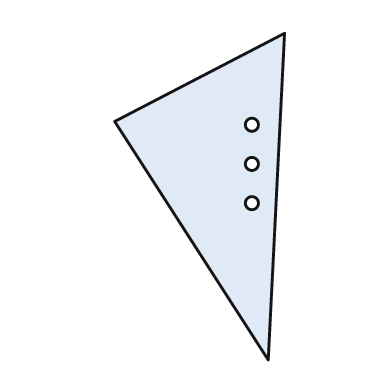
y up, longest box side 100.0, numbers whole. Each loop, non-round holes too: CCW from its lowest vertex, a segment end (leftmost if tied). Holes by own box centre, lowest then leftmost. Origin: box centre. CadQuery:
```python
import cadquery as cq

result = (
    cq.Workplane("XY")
    .moveTo(21.0, -50.0)
    .lineTo(26.0, 50.0)
    .lineTo(-26.0, 23.0)
    .close()
    .moveTo(16.0, -2.0)
    .circle(2.0)
    .moveTo(16.0, 10.0)
    .circle(2.0)
    .moveTo(16.0, 22.0)
    .circle(2.0)
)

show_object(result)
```